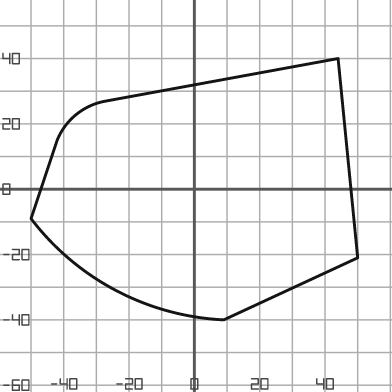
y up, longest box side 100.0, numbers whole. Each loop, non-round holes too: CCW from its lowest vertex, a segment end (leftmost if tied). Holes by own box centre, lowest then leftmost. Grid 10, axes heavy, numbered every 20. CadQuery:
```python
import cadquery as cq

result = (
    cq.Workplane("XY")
    .moveTo(9.0, -40.0)
    .lineTo(50.0, -21.0)
    .lineTo(44.0, 40.0)
    .lineTo(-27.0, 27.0)
    .threePointArc((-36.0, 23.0), (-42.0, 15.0))
    .lineTo(-50.0, -9.0)
    .threePointArc((-24.0, -31.0), (9.0, -40.0))
    .close()
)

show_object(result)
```